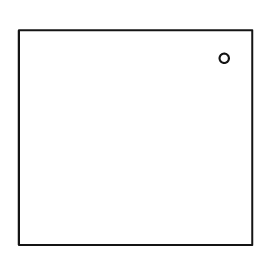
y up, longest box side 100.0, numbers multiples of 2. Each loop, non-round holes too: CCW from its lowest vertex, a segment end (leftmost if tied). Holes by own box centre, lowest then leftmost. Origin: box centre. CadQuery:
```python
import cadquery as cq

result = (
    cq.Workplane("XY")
    .moveTo(-50.0, -46.0)
    .lineTo(50.0, -46.0)
    .lineTo(50.0, 46.0)
    .lineTo(-50.0, 46.0)
    .close()
    .moveTo(38.0, 34.0)
    .circle(2.0)
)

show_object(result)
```